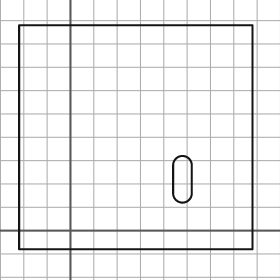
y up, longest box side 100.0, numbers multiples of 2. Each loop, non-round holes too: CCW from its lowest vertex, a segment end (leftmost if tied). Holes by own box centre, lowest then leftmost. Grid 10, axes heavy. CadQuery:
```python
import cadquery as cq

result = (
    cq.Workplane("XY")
    .moveTo(-22.0, -8.0)
    .lineTo(78.0, -8.0)
    .lineTo(78.0, 88.0)
    .lineTo(-22.0, 88.0)
    .close()
    .moveTo(44.0, 16.0)
    .threePointArc((48.0, 12.0), (52.0, 16.0))
    .lineTo(52.0, 28.0)
    .threePointArc((48.0, 32.0), (44.0, 28.0))
    .close()
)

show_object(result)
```